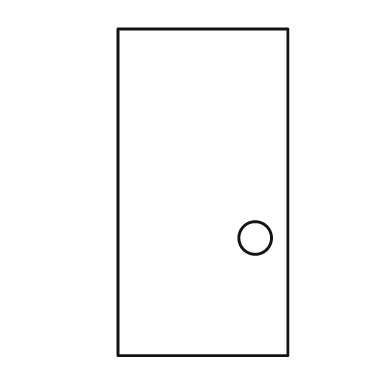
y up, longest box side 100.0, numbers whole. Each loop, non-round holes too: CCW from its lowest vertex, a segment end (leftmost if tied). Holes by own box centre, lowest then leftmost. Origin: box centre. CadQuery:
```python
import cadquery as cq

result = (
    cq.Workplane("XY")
    .moveTo(-26.0, -50.0)
    .lineTo(26.0, -50.0)
    .lineTo(26.0, 50.0)
    .lineTo(-26.0, 50.0)
    .close()
    .moveTo(16.0, -14.0)
    .circle(5.0)
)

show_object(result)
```